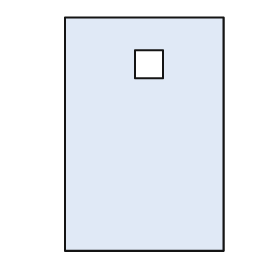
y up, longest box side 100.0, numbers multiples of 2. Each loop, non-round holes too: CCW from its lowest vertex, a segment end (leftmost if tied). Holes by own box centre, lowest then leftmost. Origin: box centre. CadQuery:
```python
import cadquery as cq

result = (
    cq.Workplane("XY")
    .moveTo(-34.0, -50.0)
    .lineTo(34.0, -50.0)
    .lineTo(34.0, 50.0)
    .lineTo(-34.0, 50.0)
    .close()
    .moveTo(-4.0, 24.0)
    .lineTo(8.0, 24.0)
    .lineTo(8.0, 36.0)
    .lineTo(-4.0, 36.0)
    .close()
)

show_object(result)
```